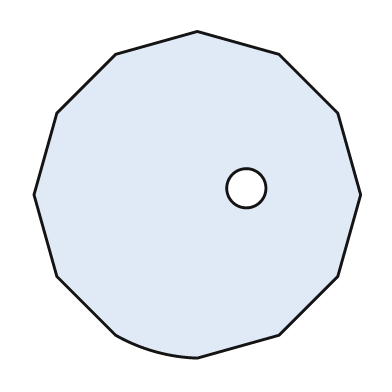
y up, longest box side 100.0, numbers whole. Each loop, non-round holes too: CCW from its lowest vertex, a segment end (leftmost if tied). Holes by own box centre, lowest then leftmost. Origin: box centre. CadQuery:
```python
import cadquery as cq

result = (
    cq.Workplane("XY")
    .moveTo(0.0, -50.0)
    .lineTo(25.0, -43.0)
    .lineTo(43.0, -25.0)
    .lineTo(50.0, 0.0)
    .lineTo(43.0, 25.0)
    .lineTo(25.0, 43.0)
    .lineTo(0.0, 50.0)
    .lineTo(-25.0, 43.0)
    .lineTo(-43.0, 25.0)
    .lineTo(-50.0, 0.0)
    .lineTo(-43.0, -25.0)
    .lineTo(-25.0, -43.0)
    .threePointArc((-13.0, -48.0), (0.0, -50.0))
    .close()
    .moveTo(15.0, 2.0)
    .circle(6.0)
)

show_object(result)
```